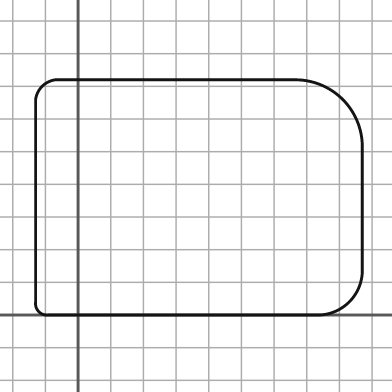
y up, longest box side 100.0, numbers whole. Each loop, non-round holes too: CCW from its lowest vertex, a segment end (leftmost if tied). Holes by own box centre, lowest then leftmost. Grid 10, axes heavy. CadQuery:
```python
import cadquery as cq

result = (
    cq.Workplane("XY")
    .moveTo(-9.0, 0.0)
    .lineTo(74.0, 0.0)
    .threePointArc((83.0, 4.0), (87.0, 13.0))
    .lineTo(87.0, 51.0)
    .threePointArc((81.0, 66.0), (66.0, 72.0))
    .lineTo(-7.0, 72.0)
    .threePointArc((-11.0, 70.0), (-13.0, 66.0))
    .lineTo(-13.0, 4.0)
    .threePointArc((-12.0, 1.0), (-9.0, 0.0))
    .close()
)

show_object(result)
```